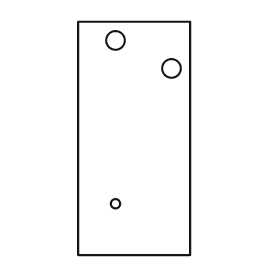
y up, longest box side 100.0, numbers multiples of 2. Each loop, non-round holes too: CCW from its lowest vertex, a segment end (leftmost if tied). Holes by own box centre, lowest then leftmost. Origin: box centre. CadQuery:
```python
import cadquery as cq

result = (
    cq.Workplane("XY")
    .moveTo(-24.0, -50.0)
    .lineTo(24.0, -50.0)
    .lineTo(24.0, 50.0)
    .lineTo(-24.0, 50.0)
    .close()
    .moveTo(-8.0, -28.0)
    .circle(2.0)
    .moveTo(16.0, 30.0)
    .circle(4.0)
    .moveTo(-8.0, 42.0)
    .circle(4.0)
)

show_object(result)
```